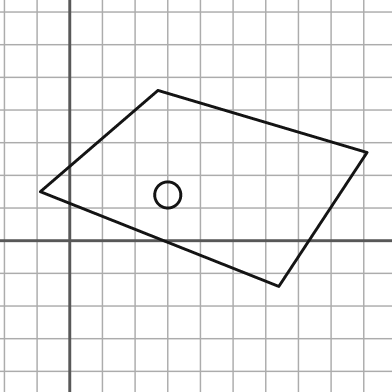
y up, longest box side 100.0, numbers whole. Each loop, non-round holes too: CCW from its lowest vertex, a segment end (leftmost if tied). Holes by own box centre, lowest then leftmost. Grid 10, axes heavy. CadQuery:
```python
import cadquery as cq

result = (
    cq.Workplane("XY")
    .moveTo(64.0, -14.0)
    .lineTo(91.0, 27.0)
    .lineTo(27.0, 46.0)
    .lineTo(-9.0, 15.0)
    .close()
    .moveTo(30.0, 14.0)
    .circle(4.0)
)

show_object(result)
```